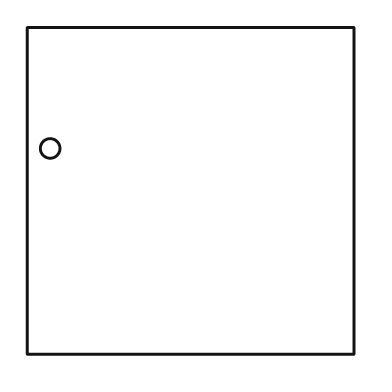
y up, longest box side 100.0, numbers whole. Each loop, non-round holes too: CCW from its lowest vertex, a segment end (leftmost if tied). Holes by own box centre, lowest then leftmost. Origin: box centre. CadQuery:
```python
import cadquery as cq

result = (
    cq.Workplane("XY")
    .moveTo(-50.0, -50.0)
    .lineTo(50.0, -50.0)
    .lineTo(50.0, 50.0)
    .lineTo(-50.0, 50.0)
    .close()
    .moveTo(-43.0, 13.0)
    .circle(3.0)
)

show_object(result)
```